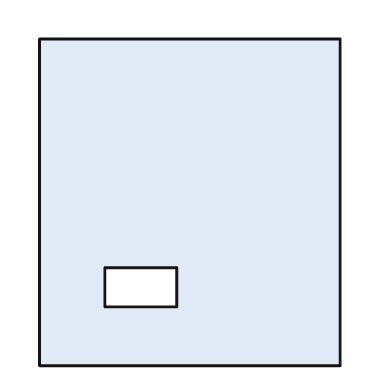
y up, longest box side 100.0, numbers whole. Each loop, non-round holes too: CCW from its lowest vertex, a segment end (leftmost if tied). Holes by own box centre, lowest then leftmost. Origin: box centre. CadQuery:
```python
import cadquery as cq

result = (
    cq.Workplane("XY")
    .moveTo(-46.0, -50.0)
    .lineTo(46.0, -50.0)
    .lineTo(46.0, 50.0)
    .lineTo(-46.0, 50.0)
    .close()
    .moveTo(-26.0, -32.0)
    .lineTo(-4.0, -32.0)
    .lineTo(-4.0, -20.0)
    .lineTo(-26.0, -20.0)
    .close()
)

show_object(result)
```